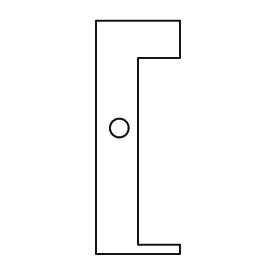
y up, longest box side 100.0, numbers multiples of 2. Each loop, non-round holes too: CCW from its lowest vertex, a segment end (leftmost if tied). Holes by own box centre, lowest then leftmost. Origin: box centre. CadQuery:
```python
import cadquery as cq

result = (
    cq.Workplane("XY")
    .moveTo(-18.0, -50.0)
    .lineTo(18.0, -50.0)
    .lineTo(18.0, -46.0)
    .lineTo(0.0, -46.0)
    .lineTo(0.0, 34.0)
    .lineTo(18.0, 34.0)
    .lineTo(18.0, 50.0)
    .lineTo(-18.0, 50.0)
    .close()
    .moveTo(-8.0, 4.0)
    .circle(4.0)
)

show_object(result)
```